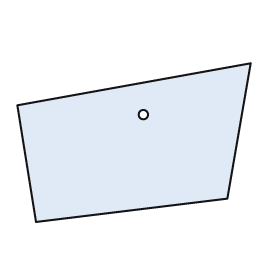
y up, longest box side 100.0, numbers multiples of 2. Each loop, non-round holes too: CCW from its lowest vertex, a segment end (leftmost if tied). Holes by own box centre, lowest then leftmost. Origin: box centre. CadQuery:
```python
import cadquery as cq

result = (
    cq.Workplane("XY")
    .moveTo(-42.0, -34.0)
    .lineTo(40.0, -24.0)
    .lineTo(50.0, 34.0)
    .lineTo(-50.0, 16.0)
    .close()
    .moveTo(4.0, 12.0)
    .circle(2.0)
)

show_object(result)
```